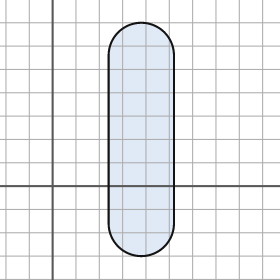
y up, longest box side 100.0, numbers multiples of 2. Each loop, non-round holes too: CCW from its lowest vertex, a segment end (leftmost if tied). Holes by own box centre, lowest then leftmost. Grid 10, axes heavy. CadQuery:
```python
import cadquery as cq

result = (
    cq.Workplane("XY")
    .moveTo(24.0, -16.0)
    .threePointArc((38.0, -30.0), (52.0, -16.0))
    .lineTo(52.0, 56.0)
    .threePointArc((38.0, 70.0), (24.0, 56.0))
    .close()
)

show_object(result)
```